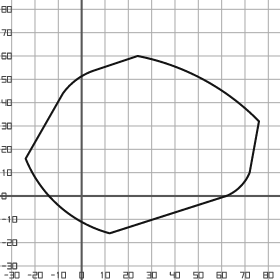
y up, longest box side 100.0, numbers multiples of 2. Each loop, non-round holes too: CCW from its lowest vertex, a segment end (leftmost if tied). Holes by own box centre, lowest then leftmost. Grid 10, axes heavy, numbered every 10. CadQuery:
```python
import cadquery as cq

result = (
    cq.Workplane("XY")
    .moveTo(12.0, -16.0)
    .lineTo(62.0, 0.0)
    .threePointArc((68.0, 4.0), (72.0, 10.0))
    .lineTo(76.0, 32.0)
    .threePointArc((52.0, 50.0), (24.0, 60.0))
    .lineTo(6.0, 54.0)
    .threePointArc((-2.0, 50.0), (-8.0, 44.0))
    .lineTo(-24.0, 16.0)
    .threePointArc((-10.0, -4.0), (12.0, -16.0))
    .close()
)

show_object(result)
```